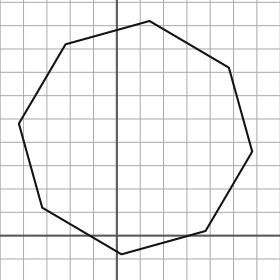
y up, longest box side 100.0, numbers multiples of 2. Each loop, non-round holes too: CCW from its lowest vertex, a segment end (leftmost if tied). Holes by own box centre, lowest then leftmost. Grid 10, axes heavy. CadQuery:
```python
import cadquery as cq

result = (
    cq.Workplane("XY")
    .moveTo(2.0, -8.0)
    .lineTo(38.0, 2.0)
    .lineTo(58.0, 36.0)
    .lineTo(48.0, 72.0)
    .lineTo(14.0, 92.0)
    .lineTo(-22.0, 82.0)
    .lineTo(-42.0, 48.0)
    .lineTo(-32.0, 12.0)
    .close()
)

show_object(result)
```